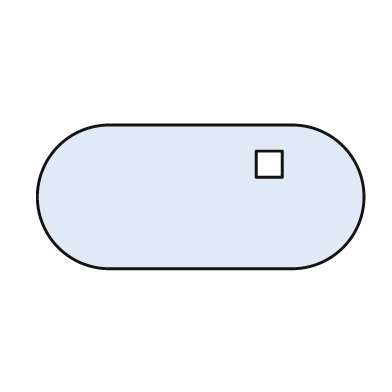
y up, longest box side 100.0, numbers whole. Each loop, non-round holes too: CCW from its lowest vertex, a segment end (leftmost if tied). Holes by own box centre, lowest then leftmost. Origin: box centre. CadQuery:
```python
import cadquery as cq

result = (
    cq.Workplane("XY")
    .moveTo(-28.0, -22.0)
    .lineTo(28.0, -22.0)
    .threePointArc((50.0, 0.0), (28.0, 22.0))
    .lineTo(-28.0, 22.0)
    .threePointArc((-50.0, 0.0), (-28.0, -22.0))
    .close()
    .moveTo(17.0, 6.0)
    .lineTo(25.0, 6.0)
    .lineTo(25.0, 14.0)
    .lineTo(17.0, 14.0)
    .close()
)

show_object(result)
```